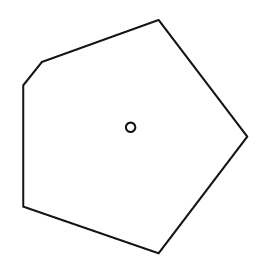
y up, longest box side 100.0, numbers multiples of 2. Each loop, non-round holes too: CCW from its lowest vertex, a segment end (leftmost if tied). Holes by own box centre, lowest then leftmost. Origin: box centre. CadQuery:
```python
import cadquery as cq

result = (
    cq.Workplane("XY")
    .moveTo(10.0, -50.0)
    .lineTo(48.0, 0.0)
    .lineTo(10.0, 50.0)
    .lineTo(-40.0, 32.0)
    .lineTo(-48.0, 22.0)
    .lineTo(-48.0, -30.0)
    .close()
    .moveTo(-2.0, 4.0)
    .circle(2.0)
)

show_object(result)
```